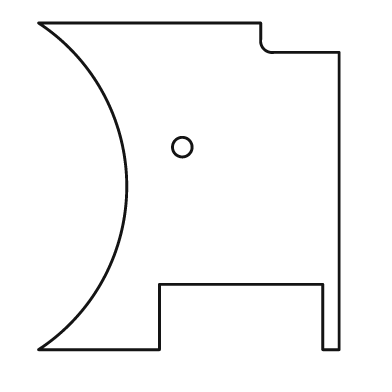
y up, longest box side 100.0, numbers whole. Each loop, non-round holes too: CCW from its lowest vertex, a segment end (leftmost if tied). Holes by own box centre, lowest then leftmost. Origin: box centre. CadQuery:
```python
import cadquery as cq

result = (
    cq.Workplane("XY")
    .moveTo(-46.0, -50.0)
    .lineTo(-9.0, -50.0)
    .lineTo(-9.0, -30.0)
    .lineTo(41.0, -30.0)
    .lineTo(41.0, -50.0)
    .lineTo(46.0, -50.0)
    .lineTo(46.0, 41.0)
    .lineTo(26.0, 41.0)
    .threePointArc((23.0, 42.0), (22.0, 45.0))
    .lineTo(22.0, 50.0)
    .lineTo(-46.0, 50.0)
    .threePointArc((-19.0, 0.0), (-46.0, -50.0))
    .close()
    .moveTo(-2.0, 12.0)
    .circle(3.0)
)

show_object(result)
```